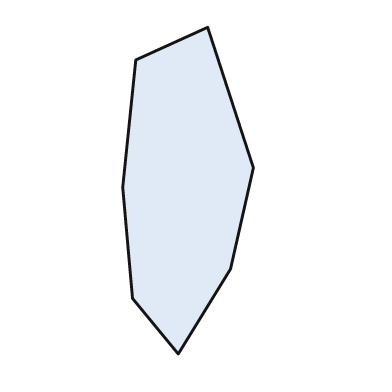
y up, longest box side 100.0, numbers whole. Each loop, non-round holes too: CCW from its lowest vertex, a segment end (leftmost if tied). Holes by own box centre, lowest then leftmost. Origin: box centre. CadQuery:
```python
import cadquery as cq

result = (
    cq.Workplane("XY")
    .moveTo(-3.0, -50.0)
    .lineTo(13.0, -24.0)
    .lineTo(20.0, 7.0)
    .lineTo(6.0, 50.0)
    .lineTo(-16.0, 40.0)
    .lineTo(-20.0, 1.0)
    .lineTo(-17.0, -33.0)
    .close()
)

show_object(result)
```